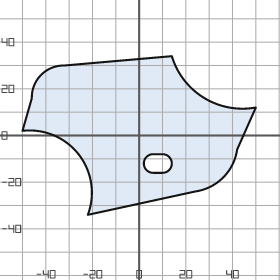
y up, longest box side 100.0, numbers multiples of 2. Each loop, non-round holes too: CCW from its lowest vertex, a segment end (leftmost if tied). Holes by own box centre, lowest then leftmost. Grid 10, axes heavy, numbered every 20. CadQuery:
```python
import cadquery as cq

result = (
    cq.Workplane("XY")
    .moveTo(-22.0, -34.0)
    .lineTo(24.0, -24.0)
    .threePointArc((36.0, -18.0), (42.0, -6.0))
    .lineTo(50.0, 12.0)
    .threePointArc((28.0, 16.0), (14.0, 34.0))
    .lineTo(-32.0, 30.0)
    .threePointArc((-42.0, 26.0), (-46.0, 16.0))
    .lineTo(-50.0, 2.0)
    .threePointArc((-26.0, -8.0), (-22.0, -34.0))
    .close()
    .moveTo(6.0, -16.0)
    .lineTo(10.0, -16.0)
    .threePointArc((14.0, -12.0), (10.0, -8.0))
    .lineTo(6.0, -8.0)
    .threePointArc((2.0, -12.0), (6.0, -16.0))
    .close()
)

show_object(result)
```